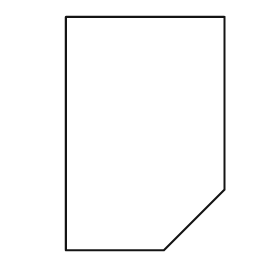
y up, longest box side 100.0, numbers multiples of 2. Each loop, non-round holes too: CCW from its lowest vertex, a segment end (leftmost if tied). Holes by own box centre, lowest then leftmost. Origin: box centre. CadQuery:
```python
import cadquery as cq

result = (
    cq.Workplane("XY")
    .moveTo(-34.0, -50.0)
    .lineTo(8.0, -50.0)
    .lineTo(34.0, -24.0)
    .lineTo(34.0, 50.0)
    .lineTo(-34.0, 50.0)
    .close()
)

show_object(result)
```